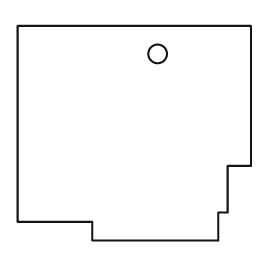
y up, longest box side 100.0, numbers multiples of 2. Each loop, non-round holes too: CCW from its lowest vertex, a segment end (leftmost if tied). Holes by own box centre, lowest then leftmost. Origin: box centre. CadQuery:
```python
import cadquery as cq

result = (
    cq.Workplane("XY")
    .moveTo(-18.0, -46.0)
    .lineTo(36.0, -46.0)
    .lineTo(36.0, -34.0)
    .lineTo(40.0, -34.0)
    .lineTo(40.0, -14.0)
    .lineTo(50.0, -14.0)
    .lineTo(50.0, 46.0)
    .lineTo(-50.0, 46.0)
    .lineTo(-50.0, -38.0)
    .lineTo(-18.0, -38.0)
    .close()
    .moveTo(10.0, 34.0)
    .circle(4.0)
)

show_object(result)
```